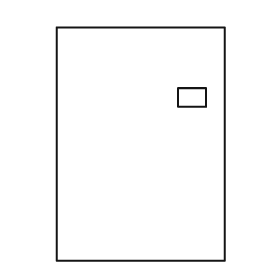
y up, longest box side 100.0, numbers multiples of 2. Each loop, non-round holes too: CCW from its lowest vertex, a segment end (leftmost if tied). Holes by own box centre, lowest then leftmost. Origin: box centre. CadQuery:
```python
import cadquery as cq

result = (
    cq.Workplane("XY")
    .moveTo(-36.0, -50.0)
    .lineTo(36.0, -50.0)
    .lineTo(36.0, 50.0)
    .lineTo(-36.0, 50.0)
    .close()
    .moveTo(16.0, 16.0)
    .lineTo(28.0, 16.0)
    .lineTo(28.0, 24.0)
    .lineTo(16.0, 24.0)
    .close()
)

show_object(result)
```